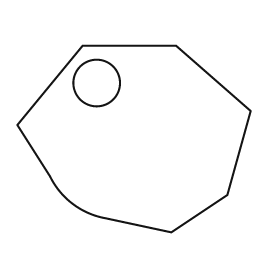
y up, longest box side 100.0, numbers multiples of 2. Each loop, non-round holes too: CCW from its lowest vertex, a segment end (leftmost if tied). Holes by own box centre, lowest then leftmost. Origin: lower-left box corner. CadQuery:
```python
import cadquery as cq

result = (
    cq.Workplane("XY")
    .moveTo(66.0, 0.0)
    .lineTo(90.0, 16.0)
    .lineTo(100.0, 52.0)
    .lineTo(68.0, 80.0)
    .lineTo(28.0, 80.0)
    .lineTo(0.0, 46.0)
    .lineTo(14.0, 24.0)
    .threePointArc((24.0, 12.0), (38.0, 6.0))
    .close()
    .moveTo(34.0, 64.0)
    .circle(10.0)
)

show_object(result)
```